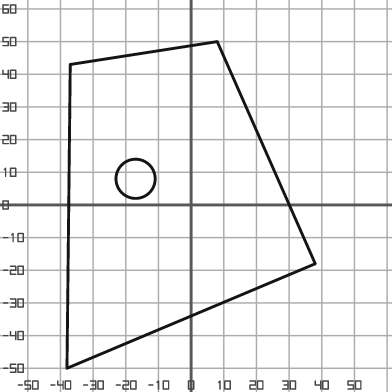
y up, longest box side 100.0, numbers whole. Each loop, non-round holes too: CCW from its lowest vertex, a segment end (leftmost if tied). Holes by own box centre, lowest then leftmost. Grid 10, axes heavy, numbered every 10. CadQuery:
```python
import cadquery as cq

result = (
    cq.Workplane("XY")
    .moveTo(-38.0, -50.0)
    .lineTo(38.0, -18.0)
    .lineTo(8.0, 50.0)
    .lineTo(-37.0, 43.0)
    .close()
    .moveTo(-17.0, 8.0)
    .circle(6.0)
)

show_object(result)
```